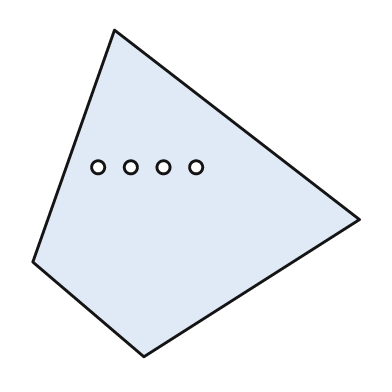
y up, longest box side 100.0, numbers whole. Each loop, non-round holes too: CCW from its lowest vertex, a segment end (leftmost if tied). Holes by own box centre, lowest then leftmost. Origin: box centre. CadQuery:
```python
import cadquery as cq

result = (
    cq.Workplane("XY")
    .moveTo(-16.0, -50.0)
    .lineTo(50.0, -8.0)
    .lineTo(-25.0, 50.0)
    .lineTo(-50.0, -21.0)
    .close()
    .moveTo(-30.0, 8.0)
    .circle(2.0)
    .moveTo(-20.0, 8.0)
    .circle(2.0)
    .moveTo(-10.0, 8.0)
    .circle(2.0)
    .moveTo(0.0, 8.0)
    .circle(2.0)
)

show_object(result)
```